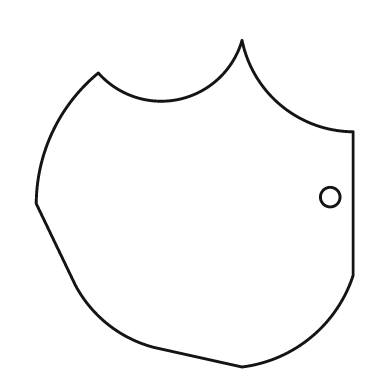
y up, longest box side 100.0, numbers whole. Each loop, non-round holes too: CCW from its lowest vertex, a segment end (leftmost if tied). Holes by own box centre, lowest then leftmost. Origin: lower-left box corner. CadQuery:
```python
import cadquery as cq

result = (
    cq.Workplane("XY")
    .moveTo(63.0, 0.0)
    .threePointArc((84.0, 9.0), (97.0, 28.0))
    .lineTo(97.0, 72.0)
    .threePointArc((75.0, 80.0), (63.0, 100.0))
    .threePointArc((44.0, 82.0), (19.0, 90.0))
    .threePointArc((5.0, 72.0), (0.0, 50.0))
    .lineTo(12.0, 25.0)
    .threePointArc((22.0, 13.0), (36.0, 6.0))
    .close()
    .moveTo(90.0, 52.0)
    .circle(3.0)
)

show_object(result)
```